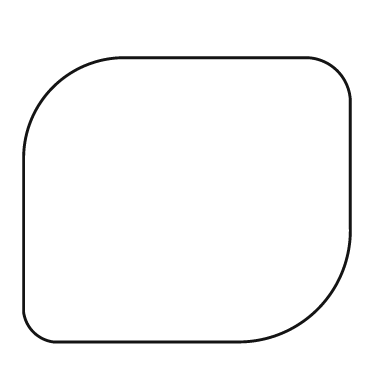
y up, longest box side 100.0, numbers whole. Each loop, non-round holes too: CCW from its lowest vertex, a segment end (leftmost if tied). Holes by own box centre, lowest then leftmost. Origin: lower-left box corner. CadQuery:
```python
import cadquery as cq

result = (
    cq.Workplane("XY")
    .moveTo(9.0, 0.0)
    .lineTo(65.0, 0.0)
    .threePointArc((90.0, 10.0), (100.0, 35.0))
    .lineTo(100.0, 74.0)
    .threePointArc((96.0, 83.0), (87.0, 87.0))
    .lineTo(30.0, 87.0)
    .threePointArc((9.0, 78.0), (0.0, 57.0))
    .lineTo(0.0, 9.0)
    .threePointArc((3.0, 3.0), (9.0, 0.0))
    .close()
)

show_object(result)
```